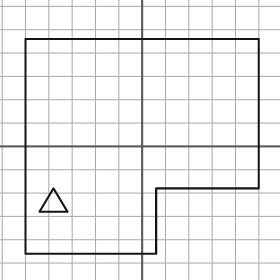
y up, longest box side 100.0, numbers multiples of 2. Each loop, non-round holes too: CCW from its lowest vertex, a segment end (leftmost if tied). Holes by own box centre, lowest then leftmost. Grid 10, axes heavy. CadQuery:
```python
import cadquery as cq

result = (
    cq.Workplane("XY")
    .moveTo(-50.0, -46.0)
    .lineTo(6.0, -46.0)
    .lineTo(6.0, -18.0)
    .lineTo(50.0, -18.0)
    .lineTo(50.0, 46.0)
    .lineTo(-50.0, 46.0)
    .close()
    .moveTo(-44.0, -28.0)
    .lineTo(-32.0, -28.0)
    .lineTo(-38.0, -18.0)
    .close()
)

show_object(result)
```